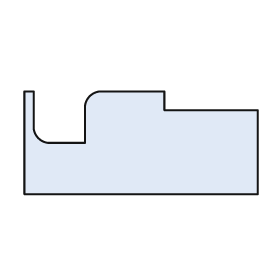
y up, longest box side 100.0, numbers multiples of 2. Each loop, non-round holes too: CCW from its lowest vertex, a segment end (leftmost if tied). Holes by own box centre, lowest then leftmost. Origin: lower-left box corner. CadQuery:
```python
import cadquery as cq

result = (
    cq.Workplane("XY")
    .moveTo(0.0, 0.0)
    .lineTo(100.0, 0.0)
    .lineTo(100.0, 36.0)
    .lineTo(60.0, 36.0)
    .lineTo(60.0, 44.0)
    .lineTo(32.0, 44.0)
    .threePointArc((28.0, 42.0), (26.0, 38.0))
    .lineTo(26.0, 22.0)
    .lineTo(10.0, 22.0)
    .threePointArc((6.0, 24.0), (4.0, 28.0))
    .lineTo(4.0, 44.0)
    .lineTo(0.0, 44.0)
    .close()
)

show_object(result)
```